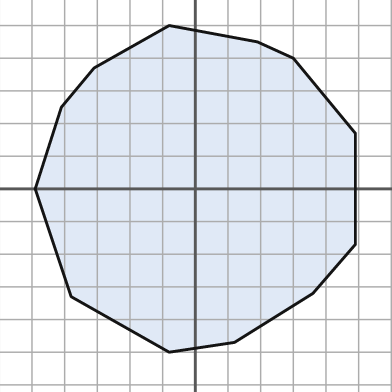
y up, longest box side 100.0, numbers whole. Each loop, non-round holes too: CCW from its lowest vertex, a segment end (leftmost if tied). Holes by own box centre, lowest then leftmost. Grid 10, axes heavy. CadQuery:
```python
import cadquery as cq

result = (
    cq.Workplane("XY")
    .moveTo(-8.0, -50.0)
    .lineTo(12.0, -47.0)
    .lineTo(36.0, -32.0)
    .lineTo(49.0, -17.0)
    .lineTo(49.0, 17.0)
    .lineTo(30.0, 40.0)
    .lineTo(19.0, 45.0)
    .lineTo(-8.0, 50.0)
    .lineTo(-31.0, 37.0)
    .lineTo(-41.0, 25.0)
    .lineTo(-49.0, 0.0)
    .lineTo(-38.0, -33.0)
    .close()
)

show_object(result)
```